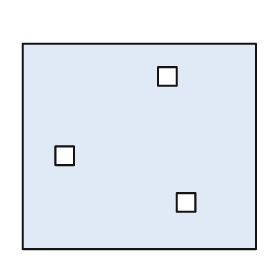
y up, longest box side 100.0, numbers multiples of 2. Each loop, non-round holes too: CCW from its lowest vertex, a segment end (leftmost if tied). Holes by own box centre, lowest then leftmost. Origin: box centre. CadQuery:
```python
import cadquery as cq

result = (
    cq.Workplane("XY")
    .moveTo(-50.0, -44.0)
    .lineTo(50.0, -44.0)
    .lineTo(50.0, 44.0)
    .lineTo(-50.0, 44.0)
    .close()
    .moveTo(16.0, -28.0)
    .lineTo(24.0, -28.0)
    .lineTo(24.0, -20.0)
    .lineTo(16.0, -20.0)
    .close()
    .moveTo(-36.0, -8.0)
    .lineTo(-28.0, -8.0)
    .lineTo(-28.0, 0.0)
    .lineTo(-36.0, 0.0)
    .close()
    .moveTo(8.0, 26.0)
    .lineTo(16.0, 26.0)
    .lineTo(16.0, 34.0)
    .lineTo(8.0, 34.0)
    .close()
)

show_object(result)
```